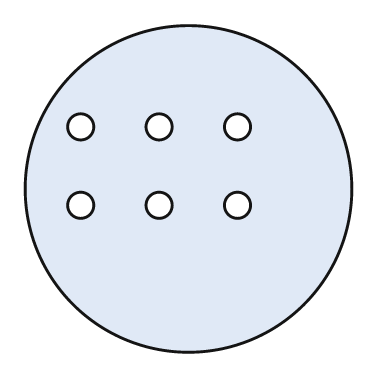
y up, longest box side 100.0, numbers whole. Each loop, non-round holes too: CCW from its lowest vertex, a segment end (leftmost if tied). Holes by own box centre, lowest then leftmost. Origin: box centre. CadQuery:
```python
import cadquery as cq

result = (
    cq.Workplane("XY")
    .moveTo(0.0, 0.0)
    .circle(50.0)
    .moveTo(-33.0, -5.0)
    .circle(4.0)
    .moveTo(-9.0, -5.0)
    .circle(4.0)
    .moveTo(15.0, -5.0)
    .circle(4.0)
    .moveTo(-33.0, 19.0)
    .circle(4.0)
    .moveTo(-9.0, 19.0)
    .circle(4.0)
    .moveTo(15.0, 19.0)
    .circle(4.0)
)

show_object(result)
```